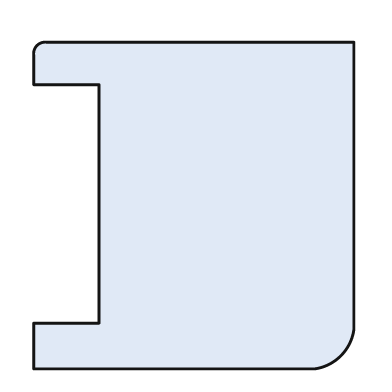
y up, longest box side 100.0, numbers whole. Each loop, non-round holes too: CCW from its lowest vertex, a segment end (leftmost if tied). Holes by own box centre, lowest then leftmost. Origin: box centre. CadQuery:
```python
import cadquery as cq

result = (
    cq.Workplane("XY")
    .moveTo(-49.0, -50.0)
    .lineTo(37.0, -50.0)
    .threePointArc((45.0, -46.0), (49.0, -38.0))
    .lineTo(49.0, 50.0)
    .lineTo(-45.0, 50.0)
    .threePointArc((-48.0, 49.0), (-49.0, 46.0))
    .lineTo(-49.0, 37.0)
    .lineTo(-29.0, 37.0)
    .lineTo(-29.0, -36.0)
    .lineTo(-49.0, -36.0)
    .close()
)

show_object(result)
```